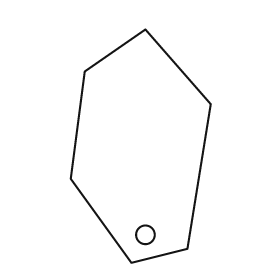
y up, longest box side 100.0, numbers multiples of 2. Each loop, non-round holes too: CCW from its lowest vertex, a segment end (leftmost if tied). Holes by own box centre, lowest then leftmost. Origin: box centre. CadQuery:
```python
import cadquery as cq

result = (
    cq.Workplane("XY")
    .moveTo(-4.0, -50.0)
    .lineTo(20.0, -44.0)
    .lineTo(30.0, 18.0)
    .lineTo(2.0, 50.0)
    .lineTo(-24.0, 32.0)
    .lineTo(-30.0, -14.0)
    .close()
    .moveTo(2.0, -38.0)
    .circle(4.0)
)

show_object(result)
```